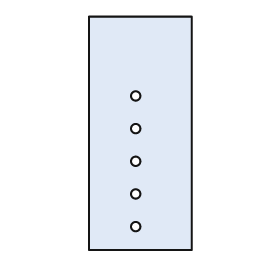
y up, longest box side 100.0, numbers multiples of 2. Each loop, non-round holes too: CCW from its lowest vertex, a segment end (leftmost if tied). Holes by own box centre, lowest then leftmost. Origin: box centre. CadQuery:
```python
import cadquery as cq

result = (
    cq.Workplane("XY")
    .moveTo(-22.0, -50.0)
    .lineTo(22.0, -50.0)
    .lineTo(22.0, 50.0)
    .lineTo(-22.0, 50.0)
    .close()
    .moveTo(-2.0, -40.0)
    .circle(2.0)
    .moveTo(-2.0, -26.0)
    .circle(2.0)
    .moveTo(-2.0, -12.0)
    .circle(2.0)
    .moveTo(-2.0, 2.0)
    .circle(2.0)
    .moveTo(-2.0, 16.0)
    .circle(2.0)
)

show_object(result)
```